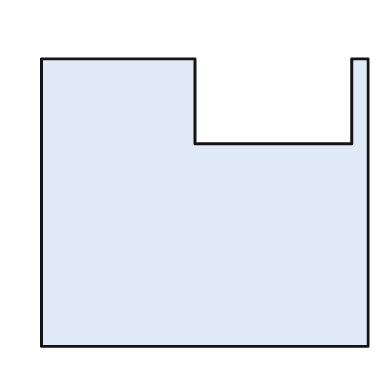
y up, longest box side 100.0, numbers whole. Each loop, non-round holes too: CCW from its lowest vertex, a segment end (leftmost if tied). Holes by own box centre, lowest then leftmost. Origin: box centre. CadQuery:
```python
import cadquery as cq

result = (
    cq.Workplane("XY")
    .moveTo(-50.0, -44.0)
    .lineTo(50.0, -44.0)
    .lineTo(50.0, 44.0)
    .lineTo(45.0, 44.0)
    .lineTo(45.0, 18.0)
    .lineTo(-3.0, 18.0)
    .lineTo(-3.0, 44.0)
    .lineTo(-50.0, 44.0)
    .close()
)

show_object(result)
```